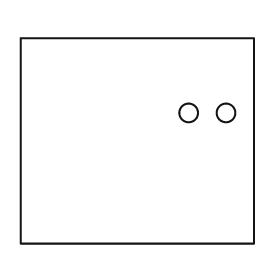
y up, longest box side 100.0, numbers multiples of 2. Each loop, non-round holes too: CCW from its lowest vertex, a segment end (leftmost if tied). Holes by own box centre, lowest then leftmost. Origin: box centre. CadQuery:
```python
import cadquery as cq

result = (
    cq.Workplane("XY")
    .moveTo(-50.0, -44.0)
    .lineTo(50.0, -44.0)
    .lineTo(50.0, 44.0)
    .lineTo(-50.0, 44.0)
    .close()
    .moveTo(22.0, 12.0)
    .circle(4.0)
    .moveTo(38.0, 12.0)
    .circle(4.0)
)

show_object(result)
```